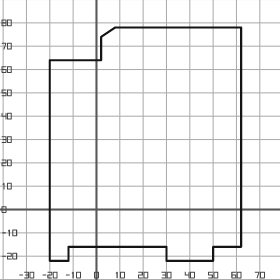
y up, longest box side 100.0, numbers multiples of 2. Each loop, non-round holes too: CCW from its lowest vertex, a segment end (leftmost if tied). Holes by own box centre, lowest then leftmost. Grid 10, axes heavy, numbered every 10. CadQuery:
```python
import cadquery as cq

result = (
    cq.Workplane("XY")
    .moveTo(-20.0, -22.0)
    .lineTo(-12.0, -22.0)
    .lineTo(-12.0, -16.0)
    .lineTo(30.0, -16.0)
    .lineTo(30.0, -22.0)
    .lineTo(50.0, -22.0)
    .lineTo(50.0, -16.0)
    .lineTo(62.0, -16.0)
    .lineTo(62.0, 78.0)
    .lineTo(8.0, 78.0)
    .lineTo(2.0, 74.0)
    .lineTo(2.0, 64.0)
    .lineTo(-20.0, 64.0)
    .close()
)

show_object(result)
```